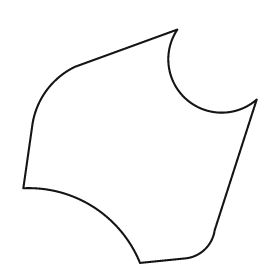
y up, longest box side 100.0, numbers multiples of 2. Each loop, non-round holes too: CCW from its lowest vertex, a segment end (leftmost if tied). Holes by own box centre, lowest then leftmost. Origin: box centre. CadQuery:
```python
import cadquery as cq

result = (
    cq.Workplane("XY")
    .moveTo(0.0, -50.0)
    .lineTo(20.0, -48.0)
    .threePointArc((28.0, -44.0), (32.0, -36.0))
    .lineTo(50.0, 20.0)
    .threePointArc((20.0, 20.0), (16.0, 50.0))
    .lineTo(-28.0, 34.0)
    .threePointArc((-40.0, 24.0), (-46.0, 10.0))
    .lineTo(-50.0, -18.0)
    .threePointArc((-20.0, -26.0), (0.0, -50.0))
    .close()
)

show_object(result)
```